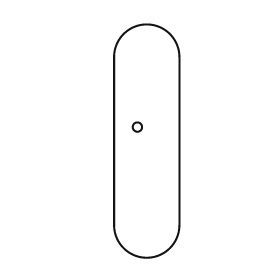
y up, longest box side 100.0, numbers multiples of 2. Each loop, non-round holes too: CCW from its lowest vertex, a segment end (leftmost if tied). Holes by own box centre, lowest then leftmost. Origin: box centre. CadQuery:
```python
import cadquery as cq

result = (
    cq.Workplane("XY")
    .moveTo(-14.0, -36.0)
    .threePointArc((0.0, -50.0), (14.0, -36.0))
    .lineTo(14.0, 36.0)
    .threePointArc((0.0, 50.0), (-14.0, 36.0))
    .close()
    .moveTo(-4.0, 6.0)
    .circle(2.0)
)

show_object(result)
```